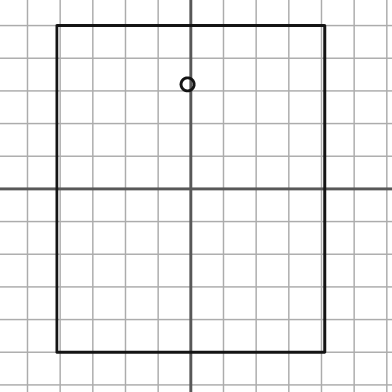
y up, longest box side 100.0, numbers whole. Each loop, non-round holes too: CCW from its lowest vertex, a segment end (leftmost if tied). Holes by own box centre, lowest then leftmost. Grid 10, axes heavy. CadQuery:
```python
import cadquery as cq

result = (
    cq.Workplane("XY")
    .moveTo(-41.0, -50.0)
    .lineTo(41.0, -50.0)
    .lineTo(41.0, 50.0)
    .lineTo(-41.0, 50.0)
    .close()
    .moveTo(-1.0, 32.0)
    .circle(2.0)
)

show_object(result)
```